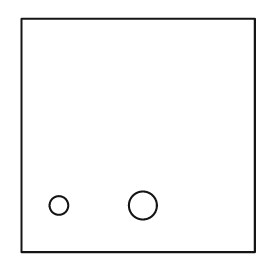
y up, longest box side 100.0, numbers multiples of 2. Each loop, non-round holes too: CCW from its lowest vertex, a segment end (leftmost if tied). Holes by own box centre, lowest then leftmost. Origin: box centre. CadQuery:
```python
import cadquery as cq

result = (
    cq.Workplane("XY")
    .moveTo(-50.0, -50.0)
    .lineTo(50.0, -50.0)
    .lineTo(50.0, 50.0)
    .lineTo(-50.0, 50.0)
    .close()
    .moveTo(-34.0, -30.0)
    .circle(4.0)
    .moveTo(2.0, -30.0)
    .circle(6.0)
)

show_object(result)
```